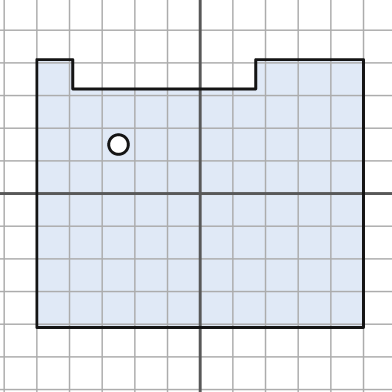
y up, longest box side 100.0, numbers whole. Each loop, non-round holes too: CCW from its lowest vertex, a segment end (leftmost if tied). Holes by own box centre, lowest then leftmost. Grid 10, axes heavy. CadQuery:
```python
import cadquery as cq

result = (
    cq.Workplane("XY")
    .moveTo(-50.0, -41.0)
    .lineTo(50.0, -41.0)
    .lineTo(50.0, 41.0)
    .lineTo(17.0, 41.0)
    .lineTo(17.0, 32.0)
    .lineTo(-39.0, 32.0)
    .lineTo(-39.0, 41.0)
    .lineTo(-50.0, 41.0)
    .close()
    .moveTo(-25.0, 15.0)
    .circle(3.0)
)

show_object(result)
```